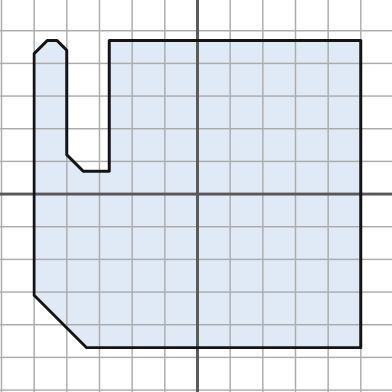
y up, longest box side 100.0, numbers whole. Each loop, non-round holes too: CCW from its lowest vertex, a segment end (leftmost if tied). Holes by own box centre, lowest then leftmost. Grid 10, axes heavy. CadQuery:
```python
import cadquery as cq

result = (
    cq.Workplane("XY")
    .moveTo(-34.0, -47.0)
    .lineTo(50.0, -47.0)
    .lineTo(50.0, 47.0)
    .lineTo(-27.0, 47.0)
    .lineTo(-27.0, 7.0)
    .lineTo(-35.0, 7.0)
    .lineTo(-40.0, 12.0)
    .lineTo(-40.0, 44.0)
    .lineTo(-43.0, 47.0)
    .lineTo(-46.0, 47.0)
    .lineTo(-50.0, 43.0)
    .lineTo(-50.0, -31.0)
    .close()
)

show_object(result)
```